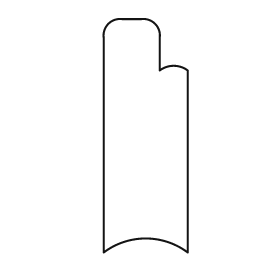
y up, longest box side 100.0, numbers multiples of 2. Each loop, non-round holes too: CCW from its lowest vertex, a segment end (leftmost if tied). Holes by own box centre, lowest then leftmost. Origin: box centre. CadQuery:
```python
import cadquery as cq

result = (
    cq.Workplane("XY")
    .moveTo(-18.0, -50.0)
    .threePointArc((0.0, -44.0), (18.0, -50.0))
    .lineTo(18.0, 28.0)
    .threePointArc((12.0, 30.0), (6.0, 28.0))
    .lineTo(6.0, 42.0)
    .threePointArc((4.0, 48.0), (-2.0, 50.0))
    .lineTo(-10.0, 50.0)
    .threePointArc((-16.0, 48.0), (-18.0, 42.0))
    .close()
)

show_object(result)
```